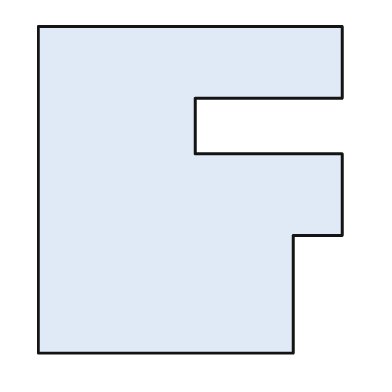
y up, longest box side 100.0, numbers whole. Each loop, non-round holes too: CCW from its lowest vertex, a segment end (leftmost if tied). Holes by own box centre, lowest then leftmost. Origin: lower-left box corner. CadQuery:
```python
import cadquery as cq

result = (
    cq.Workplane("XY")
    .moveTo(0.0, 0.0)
    .lineTo(78.0, 0.0)
    .lineTo(78.0, 36.0)
    .lineTo(93.0, 36.0)
    .lineTo(93.0, 61.0)
    .lineTo(48.0, 61.0)
    .lineTo(48.0, 78.0)
    .lineTo(93.0, 78.0)
    .lineTo(93.0, 100.0)
    .lineTo(0.0, 100.0)
    .close()
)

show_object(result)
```